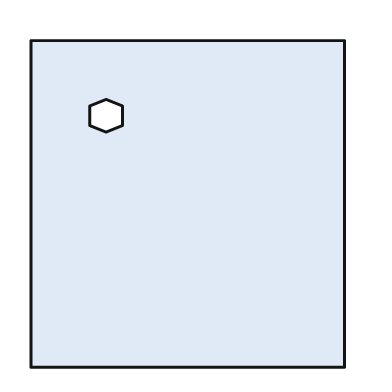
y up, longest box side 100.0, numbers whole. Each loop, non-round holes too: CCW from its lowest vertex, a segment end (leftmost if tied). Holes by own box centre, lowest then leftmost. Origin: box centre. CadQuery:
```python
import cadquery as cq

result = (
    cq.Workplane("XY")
    .moveTo(-48.0, -50.0)
    .lineTo(48.0, -50.0)
    .lineTo(48.0, 50.0)
    .lineTo(-48.0, 50.0)
    .close()
    .moveTo(-25.0, 22.0)
    .lineTo(-20.0, 24.0)
    .lineTo(-20.0, 30.0)
    .lineTo(-25.0, 32.0)
    .lineTo(-30.0, 30.0)
    .lineTo(-30.0, 24.0)
    .close()
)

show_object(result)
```